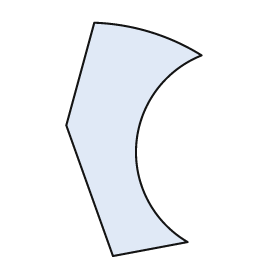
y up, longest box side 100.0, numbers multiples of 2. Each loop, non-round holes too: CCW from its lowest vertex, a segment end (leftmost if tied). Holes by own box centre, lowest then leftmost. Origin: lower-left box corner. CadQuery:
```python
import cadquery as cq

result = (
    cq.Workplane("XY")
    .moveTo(20.0, 0.0)
    .lineTo(52.0, 6.0)
    .threePointArc((30.0, 48.0), (58.0, 86.0))
    .threePointArc((36.0, 96.0), (12.0, 100.0))
    .lineTo(0.0, 56.0)
    .close()
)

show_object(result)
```